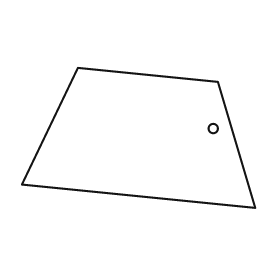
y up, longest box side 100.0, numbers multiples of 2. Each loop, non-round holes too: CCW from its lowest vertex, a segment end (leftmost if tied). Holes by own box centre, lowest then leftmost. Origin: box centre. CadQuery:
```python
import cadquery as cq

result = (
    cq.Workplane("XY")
    .moveTo(50.0, -30.0)
    .lineTo(34.0, 24.0)
    .lineTo(-26.0, 30.0)
    .lineTo(-50.0, -20.0)
    .close()
    .moveTo(32.0, 4.0)
    .circle(2.0)
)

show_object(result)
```